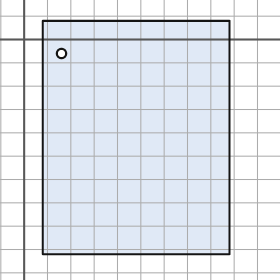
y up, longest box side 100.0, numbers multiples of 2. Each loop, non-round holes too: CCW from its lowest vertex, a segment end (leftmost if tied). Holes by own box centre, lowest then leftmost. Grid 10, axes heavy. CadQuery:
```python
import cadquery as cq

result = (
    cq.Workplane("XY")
    .moveTo(8.0, -92.0)
    .lineTo(88.0, -92.0)
    .lineTo(88.0, 8.0)
    .lineTo(8.0, 8.0)
    .close()
    .moveTo(16.0, -6.0)
    .circle(2.0)
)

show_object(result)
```